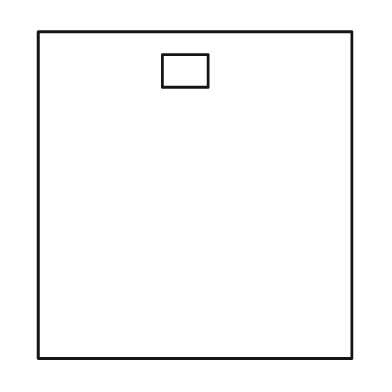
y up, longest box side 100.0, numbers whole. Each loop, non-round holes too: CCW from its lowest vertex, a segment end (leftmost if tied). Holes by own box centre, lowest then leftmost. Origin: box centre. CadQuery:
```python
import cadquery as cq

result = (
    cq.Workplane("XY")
    .moveTo(-48.0, -50.0)
    .lineTo(48.0, -50.0)
    .lineTo(48.0, 50.0)
    .lineTo(-48.0, 50.0)
    .close()
    .moveTo(-10.0, 33.0)
    .lineTo(4.0, 33.0)
    .lineTo(4.0, 43.0)
    .lineTo(-10.0, 43.0)
    .close()
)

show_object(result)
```